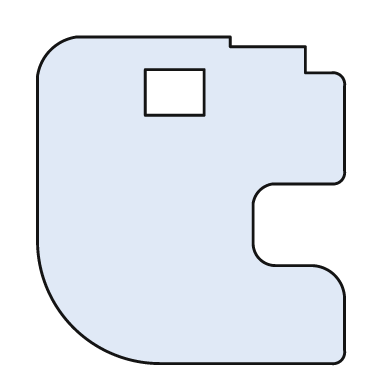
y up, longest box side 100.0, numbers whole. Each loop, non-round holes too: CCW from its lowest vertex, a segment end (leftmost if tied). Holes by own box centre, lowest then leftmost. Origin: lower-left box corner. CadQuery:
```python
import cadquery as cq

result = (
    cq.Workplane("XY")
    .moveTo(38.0, 0.0)
    .lineTo(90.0, 0.0)
    .threePointArc((93.0, 1.0), (94.0, 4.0))
    .lineTo(94.0, 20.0)
    .threePointArc((91.0, 27.0), (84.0, 30.0))
    .lineTo(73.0, 30.0)
    .threePointArc((68.0, 32.0), (66.0, 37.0))
    .lineTo(66.0, 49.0)
    .threePointArc((68.0, 53.0), (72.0, 55.0))
    .lineTo(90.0, 55.0)
    .threePointArc((93.0, 56.0), (94.0, 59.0))
    .lineTo(94.0, 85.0)
    .threePointArc((93.0, 88.0), (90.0, 89.0))
    .lineTo(82.0, 89.0)
    .lineTo(82.0, 97.0)
    .lineTo(59.0, 97.0)
    .lineTo(59.0, 100.0)
    .lineTo(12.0, 100.0)
    .threePointArc((4.0, 96.0), (0.0, 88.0))
    .lineTo(0.0, 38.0)
    .threePointArc((11.0, 11.0), (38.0, 0.0))
    .close()
    .moveTo(33.0, 76.0)
    .lineTo(51.0, 76.0)
    .lineTo(51.0, 90.0)
    .lineTo(33.0, 90.0)
    .close()
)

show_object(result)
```